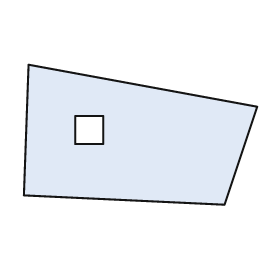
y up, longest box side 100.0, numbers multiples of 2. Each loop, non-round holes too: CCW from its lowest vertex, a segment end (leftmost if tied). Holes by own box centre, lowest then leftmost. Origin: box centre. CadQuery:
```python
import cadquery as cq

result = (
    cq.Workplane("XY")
    .moveTo(36.0, -30.0)
    .lineTo(50.0, 12.0)
    .lineTo(-48.0, 30.0)
    .lineTo(-50.0, -26.0)
    .close()
    .moveTo(-28.0, -4.0)
    .lineTo(-16.0, -4.0)
    .lineTo(-16.0, 8.0)
    .lineTo(-28.0, 8.0)
    .close()
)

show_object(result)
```